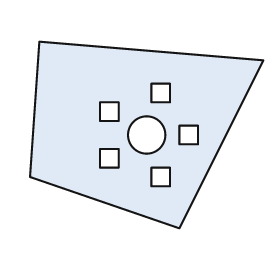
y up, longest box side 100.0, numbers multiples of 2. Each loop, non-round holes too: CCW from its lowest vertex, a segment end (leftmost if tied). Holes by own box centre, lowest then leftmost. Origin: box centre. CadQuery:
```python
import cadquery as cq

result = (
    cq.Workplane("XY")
    .moveTo(14.0, -40.0)
    .lineTo(50.0, 32.0)
    .lineTo(-46.0, 40.0)
    .lineTo(-50.0, -18.0)
    .close()
    .moveTo(2.0, -22.0)
    .lineTo(10.0, -22.0)
    .lineTo(10.0, -14.0)
    .lineTo(2.0, -14.0)
    .close()
    .moveTo(-20.0, -14.0)
    .lineTo(-12.0, -14.0)
    .lineTo(-12.0, -6.0)
    .lineTo(-20.0, -6.0)
    .close()
    .moveTo(0.0, 0.0)
    .circle(8.0)
    .moveTo(14.0, -4.0)
    .lineTo(22.0, -4.0)
    .lineTo(22.0, 4.0)
    .lineTo(14.0, 4.0)
    .close()
    .moveTo(-20.0, 6.0)
    .lineTo(-12.0, 6.0)
    .lineTo(-12.0, 14.0)
    .lineTo(-20.0, 14.0)
    .close()
    .moveTo(2.0, 14.0)
    .lineTo(10.0, 14.0)
    .lineTo(10.0, 22.0)
    .lineTo(2.0, 22.0)
    .close()
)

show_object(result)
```